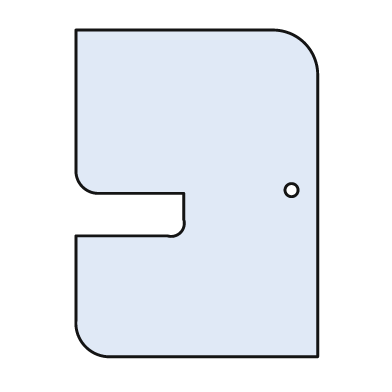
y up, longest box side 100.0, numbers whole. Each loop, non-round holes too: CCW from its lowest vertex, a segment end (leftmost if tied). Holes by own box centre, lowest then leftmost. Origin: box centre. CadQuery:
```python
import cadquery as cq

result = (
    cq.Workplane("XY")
    .moveTo(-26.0, -50.0)
    .lineTo(37.0, -50.0)
    .lineTo(37.0, 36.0)
    .threePointArc((33.0, 46.0), (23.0, 50.0))
    .lineTo(-37.0, 50.0)
    .lineTo(-37.0, 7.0)
    .threePointArc((-35.0, 2.0), (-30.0, 0.0))
    .lineTo(-4.0, 0.0)
    .lineTo(-4.0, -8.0)
    .threePointArc((-5.0, -12.0), (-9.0, -13.0))
    .lineTo(-37.0, -13.0)
    .lineTo(-37.0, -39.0)
    .threePointArc((-34.0, -47.0), (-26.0, -50.0))
    .close()
    .moveTo(29.0, 1.0)
    .circle(2.0)
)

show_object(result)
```